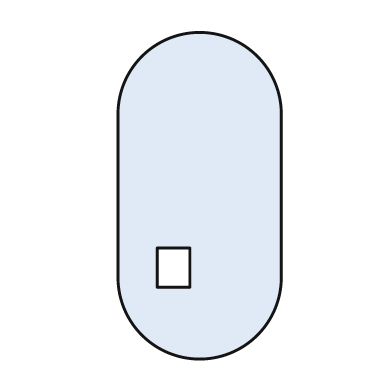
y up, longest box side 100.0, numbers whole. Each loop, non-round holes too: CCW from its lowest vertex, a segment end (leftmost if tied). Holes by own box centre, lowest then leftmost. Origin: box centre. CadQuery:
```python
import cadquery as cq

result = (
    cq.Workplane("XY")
    .moveTo(-25.0, -25.0)
    .threePointArc((0.0, -50.0), (25.0, -25.0))
    .lineTo(25.0, 25.0)
    .threePointArc((0.0, 50.0), (-25.0, 25.0))
    .close()
    .moveTo(-13.0, -28.0)
    .lineTo(-3.0, -28.0)
    .lineTo(-3.0, -16.0)
    .lineTo(-13.0, -16.0)
    .close()
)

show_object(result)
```